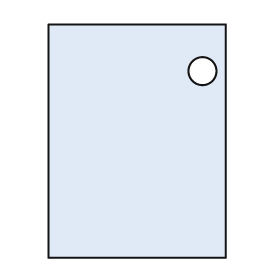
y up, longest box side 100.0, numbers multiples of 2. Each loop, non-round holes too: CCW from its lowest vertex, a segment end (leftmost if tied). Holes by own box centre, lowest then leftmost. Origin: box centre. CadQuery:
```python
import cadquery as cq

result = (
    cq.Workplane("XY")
    .moveTo(-38.0, -50.0)
    .lineTo(38.0, -50.0)
    .lineTo(38.0, 50.0)
    .lineTo(-38.0, 50.0)
    .close()
    .moveTo(28.0, 30.0)
    .circle(6.0)
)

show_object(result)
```